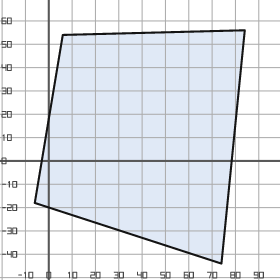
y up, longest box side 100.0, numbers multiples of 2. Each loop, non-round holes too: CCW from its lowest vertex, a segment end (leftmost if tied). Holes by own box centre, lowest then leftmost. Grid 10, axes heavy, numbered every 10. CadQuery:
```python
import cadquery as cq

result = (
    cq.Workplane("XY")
    .moveTo(74.0, -44.0)
    .lineTo(84.0, 56.0)
    .lineTo(6.0, 54.0)
    .lineTo(-6.0, -18.0)
    .close()
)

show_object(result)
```